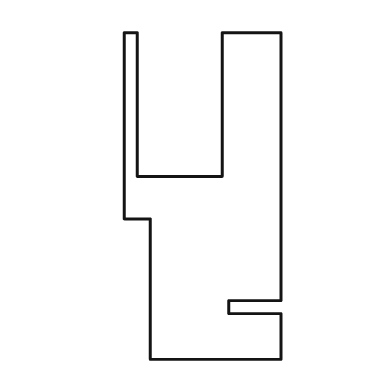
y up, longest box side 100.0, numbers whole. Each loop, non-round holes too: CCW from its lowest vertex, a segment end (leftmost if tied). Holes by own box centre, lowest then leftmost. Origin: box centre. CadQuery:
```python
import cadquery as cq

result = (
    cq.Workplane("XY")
    .moveTo(-16.0, -50.0)
    .lineTo(24.0, -50.0)
    .lineTo(24.0, -36.0)
    .lineTo(8.0, -36.0)
    .lineTo(8.0, -32.0)
    .lineTo(24.0, -32.0)
    .lineTo(24.0, 50.0)
    .lineTo(6.0, 50.0)
    .lineTo(6.0, 6.0)
    .lineTo(-20.0, 6.0)
    .lineTo(-20.0, 50.0)
    .lineTo(-24.0, 50.0)
    .lineTo(-24.0, -7.0)
    .lineTo(-16.0, -7.0)
    .close()
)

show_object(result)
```